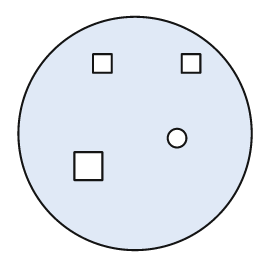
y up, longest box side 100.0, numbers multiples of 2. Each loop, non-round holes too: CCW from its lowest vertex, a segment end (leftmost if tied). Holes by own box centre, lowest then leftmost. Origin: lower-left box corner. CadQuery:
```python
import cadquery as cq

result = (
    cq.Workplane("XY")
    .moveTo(50.0, 50.0)
    .circle(50.0)
    .moveTo(24.0, 30.0)
    .lineTo(36.0, 30.0)
    .lineTo(36.0, 42.0)
    .lineTo(24.0, 42.0)
    .close()
    .moveTo(68.0, 48.0)
    .circle(4.0)
    .moveTo(32.0, 76.0)
    .lineTo(40.0, 76.0)
    .lineTo(40.0, 84.0)
    .lineTo(32.0, 84.0)
    .close()
    .moveTo(70.0, 76.0)
    .lineTo(78.0, 76.0)
    .lineTo(78.0, 84.0)
    .lineTo(70.0, 84.0)
    .close()
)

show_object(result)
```